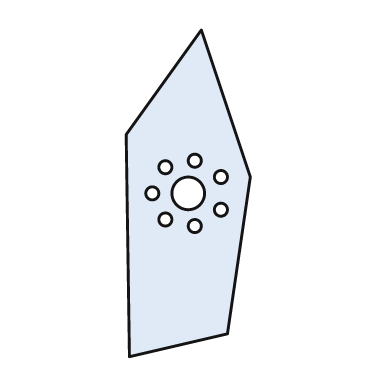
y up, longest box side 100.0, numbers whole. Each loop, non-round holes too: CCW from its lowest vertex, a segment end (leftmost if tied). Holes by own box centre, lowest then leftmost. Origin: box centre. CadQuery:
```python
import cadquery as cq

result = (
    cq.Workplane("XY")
    .moveTo(-18.0, -50.0)
    .lineTo(12.0, -43.0)
    .lineTo(19.0, 5.0)
    .lineTo(4.0, 50.0)
    .lineTo(-19.0, 18.0)
    .close()
    .moveTo(2.0, -10.0)
    .circle(2.0)
    .moveTo(-7.0, -8.0)
    .circle(2.0)
    .moveTo(10.0, -5.0)
    .circle(2.0)
    .moveTo(-11.0, 0.0)
    .circle(2.0)
    .moveTo(0.0, 0.0)
    .circle(5.0)
    .moveTo(10.0, 5.0)
    .circle(2.0)
    .moveTo(-7.0, 8.0)
    .circle(2.0)
    .moveTo(2.0, 10.0)
    .circle(2.0)
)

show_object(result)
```